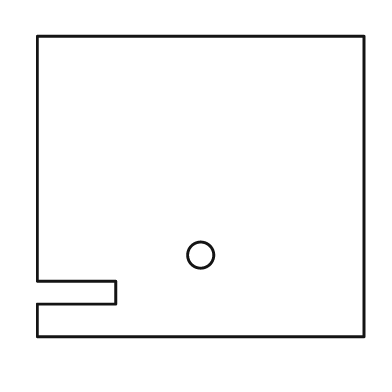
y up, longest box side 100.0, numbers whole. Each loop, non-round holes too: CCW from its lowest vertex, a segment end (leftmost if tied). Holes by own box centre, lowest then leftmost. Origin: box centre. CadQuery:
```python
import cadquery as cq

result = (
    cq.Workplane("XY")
    .moveTo(-50.0, -46.0)
    .lineTo(50.0, -46.0)
    .lineTo(50.0, 46.0)
    .lineTo(-50.0, 46.0)
    .lineTo(-50.0, -29.0)
    .lineTo(-26.0, -29.0)
    .lineTo(-26.0, -36.0)
    .lineTo(-50.0, -36.0)
    .close()
    .moveTo(0.0, -21.0)
    .circle(4.0)
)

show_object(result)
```